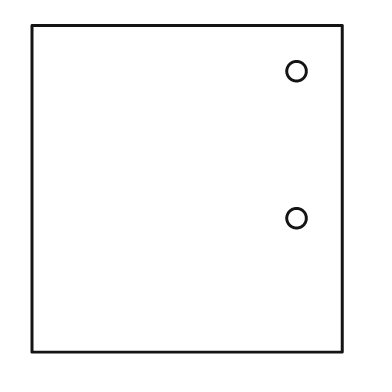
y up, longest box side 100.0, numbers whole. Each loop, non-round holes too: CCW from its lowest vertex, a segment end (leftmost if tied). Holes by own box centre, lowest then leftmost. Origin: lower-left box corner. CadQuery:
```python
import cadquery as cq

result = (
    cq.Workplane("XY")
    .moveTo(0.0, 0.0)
    .lineTo(95.0, 0.0)
    .lineTo(95.0, 100.0)
    .lineTo(0.0, 100.0)
    .close()
    .moveTo(81.0, 41.0)
    .circle(3.0)
    .moveTo(81.0, 86.0)
    .circle(3.0)
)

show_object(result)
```